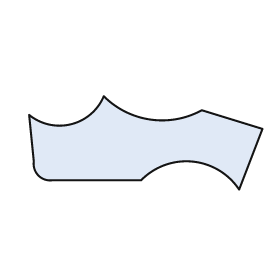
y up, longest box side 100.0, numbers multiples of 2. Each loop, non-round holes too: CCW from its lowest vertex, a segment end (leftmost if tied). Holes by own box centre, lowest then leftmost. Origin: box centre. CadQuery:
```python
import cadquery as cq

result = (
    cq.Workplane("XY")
    .moveTo(40.0, -20.0)
    .lineTo(50.0, 6.0)
    .lineTo(24.0, 14.0)
    .threePointArc((2.0, 10.0), (-18.0, 20.0))
    .threePointArc((-32.0, 8.0), (-50.0, 12.0))
    .lineTo(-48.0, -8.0)
    .threePointArc((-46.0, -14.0), (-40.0, -16.0))
    .lineTo(-2.0, -16.0)
    .threePointArc((20.0, -8.0), (40.0, -20.0))
    .close()
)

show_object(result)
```